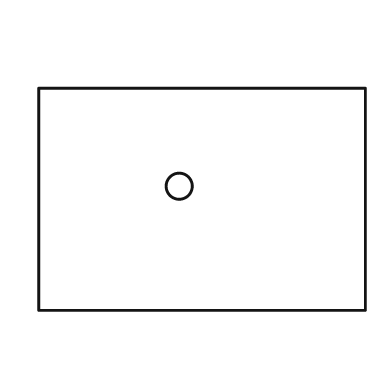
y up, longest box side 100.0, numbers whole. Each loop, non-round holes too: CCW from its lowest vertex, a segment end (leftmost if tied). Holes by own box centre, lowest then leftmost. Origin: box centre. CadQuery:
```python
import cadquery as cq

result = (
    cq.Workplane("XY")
    .moveTo(-50.0, -34.0)
    .lineTo(50.0, -34.0)
    .lineTo(50.0, 34.0)
    .lineTo(-50.0, 34.0)
    .close()
    .moveTo(-7.0, 4.0)
    .circle(4.0)
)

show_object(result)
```